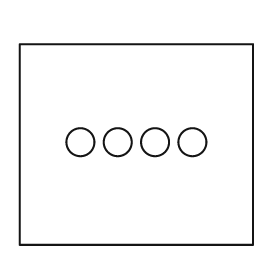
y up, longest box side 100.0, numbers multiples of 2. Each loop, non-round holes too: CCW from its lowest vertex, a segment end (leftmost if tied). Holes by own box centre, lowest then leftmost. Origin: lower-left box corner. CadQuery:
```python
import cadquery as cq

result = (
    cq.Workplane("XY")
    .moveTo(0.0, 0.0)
    .lineTo(100.0, 0.0)
    .lineTo(100.0, 86.0)
    .lineTo(0.0, 86.0)
    .close()
    .moveTo(26.0, 44.0)
    .circle(6.0)
    .moveTo(42.0, 44.0)
    .circle(6.0)
    .moveTo(58.0, 44.0)
    .circle(6.0)
    .moveTo(74.0, 44.0)
    .circle(6.0)
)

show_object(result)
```